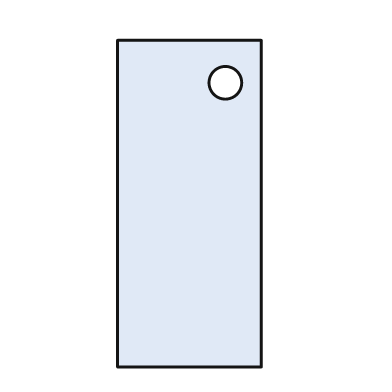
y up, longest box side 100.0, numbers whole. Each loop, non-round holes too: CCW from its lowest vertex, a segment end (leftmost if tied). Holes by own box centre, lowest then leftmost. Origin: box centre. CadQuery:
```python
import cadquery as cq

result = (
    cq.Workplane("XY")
    .moveTo(-22.0, -50.0)
    .lineTo(22.0, -50.0)
    .lineTo(22.0, 50.0)
    .lineTo(-22.0, 50.0)
    .close()
    .moveTo(11.0, 37.0)
    .circle(5.0)
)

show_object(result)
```